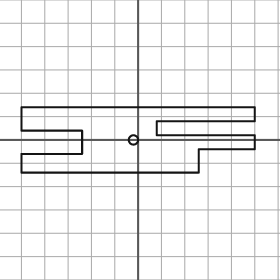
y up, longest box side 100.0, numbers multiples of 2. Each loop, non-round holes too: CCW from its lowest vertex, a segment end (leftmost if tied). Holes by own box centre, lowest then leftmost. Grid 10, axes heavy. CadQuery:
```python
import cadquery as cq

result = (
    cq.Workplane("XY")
    .moveTo(-50.0, -14.0)
    .lineTo(26.0, -14.0)
    .lineTo(26.0, -4.0)
    .lineTo(50.0, -4.0)
    .lineTo(50.0, 2.0)
    .lineTo(8.0, 2.0)
    .lineTo(8.0, 8.0)
    .lineTo(50.0, 8.0)
    .lineTo(50.0, 14.0)
    .lineTo(-50.0, 14.0)
    .lineTo(-50.0, 4.0)
    .lineTo(-24.0, 4.0)
    .lineTo(-24.0, -6.0)
    .lineTo(-50.0, -6.0)
    .close()
    .moveTo(-2.0, 0.0)
    .circle(2.0)
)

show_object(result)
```